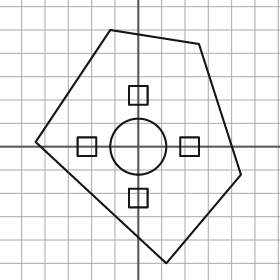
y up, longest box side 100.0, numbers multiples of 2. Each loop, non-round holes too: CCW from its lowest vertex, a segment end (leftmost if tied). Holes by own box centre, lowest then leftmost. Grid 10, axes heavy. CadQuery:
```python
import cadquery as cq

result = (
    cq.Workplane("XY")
    .moveTo(12.0, -50.0)
    .lineTo(44.0, -12.0)
    .lineTo(26.0, 44.0)
    .lineTo(-12.0, 50.0)
    .lineTo(-44.0, 2.0)
    .close()
    .moveTo(-4.0, -26.0)
    .lineTo(4.0, -26.0)
    .lineTo(4.0, -18.0)
    .lineTo(-4.0, -18.0)
    .close()
    .moveTo(-26.0, -4.0)
    .lineTo(-18.0, -4.0)
    .lineTo(-18.0, 4.0)
    .lineTo(-26.0, 4.0)
    .close()
    .moveTo(0.0, 0.0)
    .circle(12.0)
    .moveTo(18.0, -4.0)
    .lineTo(26.0, -4.0)
    .lineTo(26.0, 4.0)
    .lineTo(18.0, 4.0)
    .close()
    .moveTo(-4.0, 18.0)
    .lineTo(4.0, 18.0)
    .lineTo(4.0, 26.0)
    .lineTo(-4.0, 26.0)
    .close()
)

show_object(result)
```